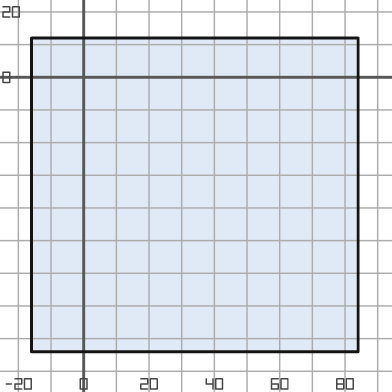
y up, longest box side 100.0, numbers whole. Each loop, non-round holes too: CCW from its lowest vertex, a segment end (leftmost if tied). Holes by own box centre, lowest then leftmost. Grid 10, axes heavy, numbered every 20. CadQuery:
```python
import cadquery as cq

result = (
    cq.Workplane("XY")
    .moveTo(-16.0, -84.0)
    .lineTo(84.0, -84.0)
    .lineTo(84.0, 12.0)
    .lineTo(-16.0, 12.0)
    .close()
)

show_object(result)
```